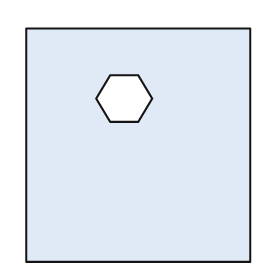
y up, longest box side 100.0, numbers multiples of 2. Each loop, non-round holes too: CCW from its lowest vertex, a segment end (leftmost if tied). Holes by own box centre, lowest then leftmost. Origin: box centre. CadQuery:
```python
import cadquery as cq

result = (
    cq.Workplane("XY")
    .moveTo(-48.0, -50.0)
    .lineTo(48.0, -50.0)
    .lineTo(48.0, 50.0)
    .lineTo(-48.0, 50.0)
    .close()
    .moveTo(-12.0, 10.0)
    .lineTo(0.0, 10.0)
    .lineTo(6.0, 20.0)
    .lineTo(0.0, 30.0)
    .lineTo(-12.0, 30.0)
    .lineTo(-18.0, 20.0)
    .close()
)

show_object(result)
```